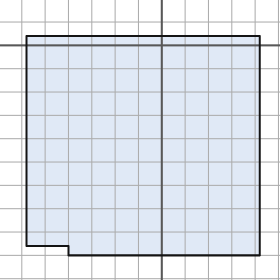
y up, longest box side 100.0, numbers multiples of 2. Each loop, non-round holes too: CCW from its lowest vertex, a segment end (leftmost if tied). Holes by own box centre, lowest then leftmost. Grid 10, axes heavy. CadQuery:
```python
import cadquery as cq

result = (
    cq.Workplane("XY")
    .moveTo(-40.0, -90.0)
    .lineTo(42.0, -90.0)
    .lineTo(42.0, 4.0)
    .lineTo(-58.0, 4.0)
    .lineTo(-58.0, -86.0)
    .lineTo(-40.0, -86.0)
    .close()
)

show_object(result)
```